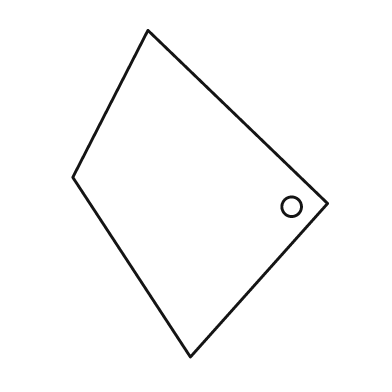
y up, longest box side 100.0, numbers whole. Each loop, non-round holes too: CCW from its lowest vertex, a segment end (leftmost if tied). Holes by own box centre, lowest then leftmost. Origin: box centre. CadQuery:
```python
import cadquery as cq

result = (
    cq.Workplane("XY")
    .moveTo(-3.0, -50.0)
    .lineTo(39.0, -3.0)
    .lineTo(-16.0, 50.0)
    .lineTo(-39.0, 5.0)
    .close()
    .moveTo(28.0, -4.0)
    .circle(3.0)
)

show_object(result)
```